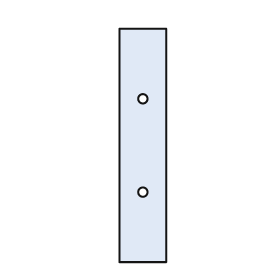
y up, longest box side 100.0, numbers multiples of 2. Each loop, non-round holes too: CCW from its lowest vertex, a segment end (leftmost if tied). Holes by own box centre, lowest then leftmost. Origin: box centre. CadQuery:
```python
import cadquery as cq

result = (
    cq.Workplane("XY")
    .moveTo(-10.0, -50.0)
    .lineTo(10.0, -50.0)
    .lineTo(10.0, 50.0)
    .lineTo(-10.0, 50.0)
    .close()
    .moveTo(0.0, -20.0)
    .circle(2.0)
    .moveTo(0.0, 20.0)
    .circle(2.0)
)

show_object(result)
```